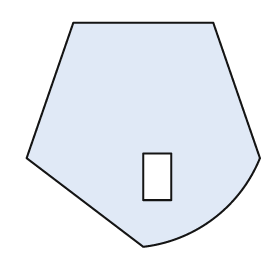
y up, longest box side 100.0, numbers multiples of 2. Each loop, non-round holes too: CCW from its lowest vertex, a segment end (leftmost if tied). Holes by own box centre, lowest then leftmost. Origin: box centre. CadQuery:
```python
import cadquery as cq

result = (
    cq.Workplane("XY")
    .moveTo(0.0, -48.0)
    .threePointArc((30.0, -36.0), (50.0, -10.0))
    .lineTo(30.0, 48.0)
    .lineTo(-30.0, 48.0)
    .lineTo(-50.0, -10.0)
    .close()
    .moveTo(0.0, -28.0)
    .lineTo(12.0, -28.0)
    .lineTo(12.0, -8.0)
    .lineTo(0.0, -8.0)
    .close()
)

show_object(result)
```